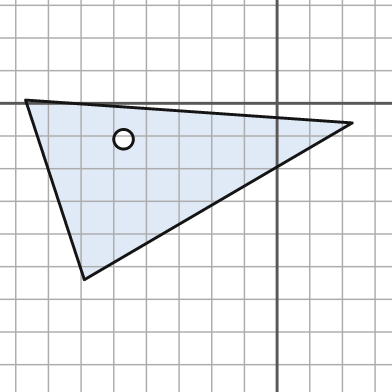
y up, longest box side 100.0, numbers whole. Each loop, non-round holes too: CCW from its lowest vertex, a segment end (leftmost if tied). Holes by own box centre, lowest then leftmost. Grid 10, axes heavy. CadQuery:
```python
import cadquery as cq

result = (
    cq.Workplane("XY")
    .moveTo(-59.0, -54.0)
    .lineTo(23.0, -6.0)
    .lineTo(-77.0, 1.0)
    .close()
    .moveTo(-47.0, -11.0)
    .circle(3.0)
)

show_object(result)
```